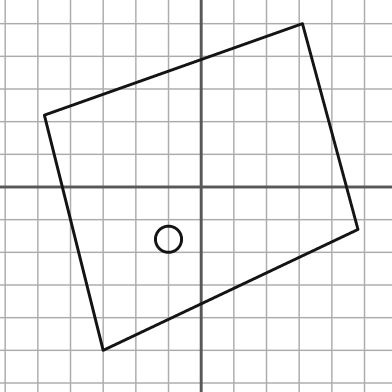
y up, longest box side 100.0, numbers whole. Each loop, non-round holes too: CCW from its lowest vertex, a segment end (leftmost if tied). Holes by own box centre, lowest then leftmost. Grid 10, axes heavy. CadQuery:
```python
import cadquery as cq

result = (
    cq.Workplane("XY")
    .moveTo(-30.0, -50.0)
    .lineTo(48.0, -13.0)
    .lineTo(31.0, 50.0)
    .lineTo(-48.0, 22.0)
    .close()
    .moveTo(-10.0, -16.0)
    .circle(4.0)
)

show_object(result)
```